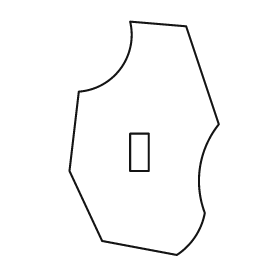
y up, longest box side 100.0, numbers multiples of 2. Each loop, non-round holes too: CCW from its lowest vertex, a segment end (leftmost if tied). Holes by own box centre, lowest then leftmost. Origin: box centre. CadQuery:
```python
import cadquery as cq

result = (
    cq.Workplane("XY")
    .moveTo(14.0, -50.0)
    .threePointArc((22.0, -42.0), (26.0, -32.0))
    .threePointArc((24.0, -12.0), (32.0, 6.0))
    .lineTo(18.0, 48.0)
    .lineTo(-6.0, 50.0)
    .threePointArc((-10.0, 30.0), (-28.0, 20.0))
    .lineTo(-32.0, -14.0)
    .lineTo(-18.0, -44.0)
    .close()
    .moveTo(-6.0, -14.0)
    .lineTo(2.0, -14.0)
    .lineTo(2.0, 2.0)
    .lineTo(-6.0, 2.0)
    .close()
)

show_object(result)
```